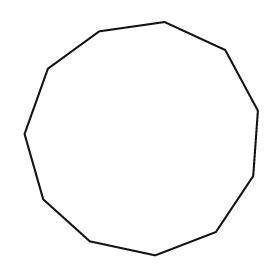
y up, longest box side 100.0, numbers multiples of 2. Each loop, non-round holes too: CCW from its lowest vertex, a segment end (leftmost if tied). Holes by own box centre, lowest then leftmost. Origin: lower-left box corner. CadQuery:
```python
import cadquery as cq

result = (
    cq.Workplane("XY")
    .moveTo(56.0, 0.0)
    .lineTo(82.0, 10.0)
    .lineTo(98.0, 34.0)
    .lineTo(100.0, 62.0)
    .lineTo(86.0, 88.0)
    .lineTo(60.0, 100.0)
    .lineTo(32.0, 96.0)
    .lineTo(10.0, 80.0)
    .lineTo(0.0, 52.0)
    .lineTo(8.0, 24.0)
    .lineTo(28.0, 6.0)
    .close()
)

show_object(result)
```